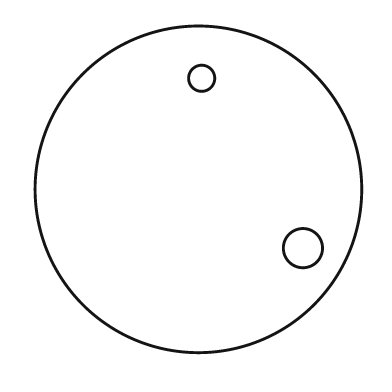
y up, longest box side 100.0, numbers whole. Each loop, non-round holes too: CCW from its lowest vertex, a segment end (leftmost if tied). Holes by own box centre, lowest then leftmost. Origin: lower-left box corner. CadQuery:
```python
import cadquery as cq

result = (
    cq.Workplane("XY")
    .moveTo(50.0, 50.0)
    .circle(50.0)
    .moveTo(82.0, 32.0)
    .circle(6.0)
    .moveTo(51.0, 84.0)
    .circle(4.0)
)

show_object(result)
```